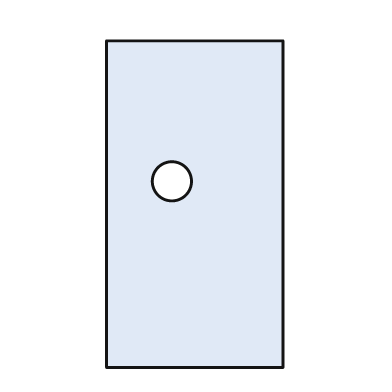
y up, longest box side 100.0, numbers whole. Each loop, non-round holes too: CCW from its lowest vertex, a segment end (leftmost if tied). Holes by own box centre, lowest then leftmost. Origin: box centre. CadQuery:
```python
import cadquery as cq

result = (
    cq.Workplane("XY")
    .moveTo(-27.0, -50.0)
    .lineTo(27.0, -50.0)
    .lineTo(27.0, 50.0)
    .lineTo(-27.0, 50.0)
    .close()
    .moveTo(-7.0, 7.0)
    .circle(6.0)
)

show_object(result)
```